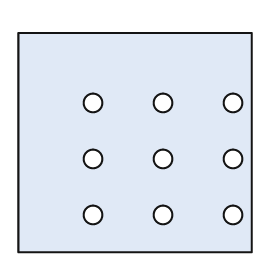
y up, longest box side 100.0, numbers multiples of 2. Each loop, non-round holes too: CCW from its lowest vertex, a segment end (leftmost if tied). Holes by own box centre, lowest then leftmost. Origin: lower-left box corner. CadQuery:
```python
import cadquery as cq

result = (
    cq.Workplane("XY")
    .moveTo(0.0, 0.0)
    .lineTo(100.0, 0.0)
    .lineTo(100.0, 94.0)
    .lineTo(0.0, 94.0)
    .close()
    .moveTo(32.0, 16.0)
    .circle(4.0)
    .moveTo(62.0, 16.0)
    .circle(4.0)
    .moveTo(92.0, 16.0)
    .circle(4.0)
    .moveTo(32.0, 40.0)
    .circle(4.0)
    .moveTo(62.0, 40.0)
    .circle(4.0)
    .moveTo(92.0, 40.0)
    .circle(4.0)
    .moveTo(32.0, 64.0)
    .circle(4.0)
    .moveTo(62.0, 64.0)
    .circle(4.0)
    .moveTo(92.0, 64.0)
    .circle(4.0)
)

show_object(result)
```